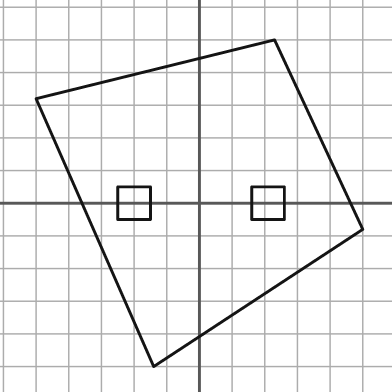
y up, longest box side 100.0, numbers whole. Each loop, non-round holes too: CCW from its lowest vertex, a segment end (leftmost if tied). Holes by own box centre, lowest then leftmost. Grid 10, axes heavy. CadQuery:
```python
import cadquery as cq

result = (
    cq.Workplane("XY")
    .moveTo(-14.0, -50.0)
    .lineTo(50.0, -8.0)
    .lineTo(23.0, 50.0)
    .lineTo(-50.0, 32.0)
    .close()
    .moveTo(-25.0, -5.0)
    .lineTo(-15.0, -5.0)
    .lineTo(-15.0, 5.0)
    .lineTo(-25.0, 5.0)
    .close()
    .moveTo(16.0, -5.0)
    .lineTo(26.0, -5.0)
    .lineTo(26.0, 5.0)
    .lineTo(16.0, 5.0)
    .close()
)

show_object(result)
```